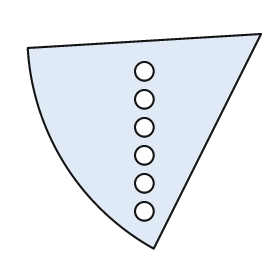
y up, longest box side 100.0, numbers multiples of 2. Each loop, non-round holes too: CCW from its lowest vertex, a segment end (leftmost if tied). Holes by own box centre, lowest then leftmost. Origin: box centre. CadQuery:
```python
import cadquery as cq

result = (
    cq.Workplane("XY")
    .moveTo(4.0, -46.0)
    .lineTo(50.0, 46.0)
    .lineTo(-50.0, 40.0)
    .threePointArc((-34.0, -10.0), (4.0, -46.0))
    .close()
    .moveTo(0.0, -30.0)
    .circle(4.0)
    .moveTo(0.0, -18.0)
    .circle(4.0)
    .moveTo(0.0, -6.0)
    .circle(4.0)
    .moveTo(0.0, 6.0)
    .circle(4.0)
    .moveTo(0.0, 18.0)
    .circle(4.0)
    .moveTo(0.0, 30.0)
    .circle(4.0)
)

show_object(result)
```